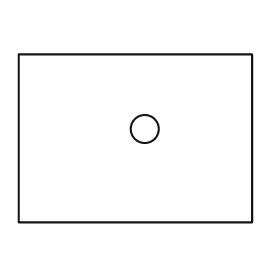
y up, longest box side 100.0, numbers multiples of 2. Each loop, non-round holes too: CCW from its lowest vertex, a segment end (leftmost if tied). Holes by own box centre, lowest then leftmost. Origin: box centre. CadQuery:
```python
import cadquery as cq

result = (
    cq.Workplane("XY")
    .moveTo(-50.0, -36.0)
    .lineTo(50.0, -36.0)
    .lineTo(50.0, 36.0)
    .lineTo(-50.0, 36.0)
    .close()
    .moveTo(4.0, 4.0)
    .circle(6.0)
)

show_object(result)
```